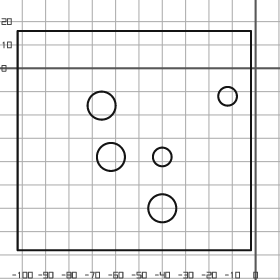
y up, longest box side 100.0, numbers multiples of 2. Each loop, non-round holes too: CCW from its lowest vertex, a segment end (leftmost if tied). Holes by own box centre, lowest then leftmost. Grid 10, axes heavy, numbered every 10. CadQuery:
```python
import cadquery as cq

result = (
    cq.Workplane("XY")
    .moveTo(-102.0, -78.0)
    .lineTo(-2.0, -78.0)
    .lineTo(-2.0, 16.0)
    .lineTo(-102.0, 16.0)
    .close()
    .moveTo(-40.0, -60.0)
    .circle(6.0)
    .moveTo(-62.0, -38.0)
    .circle(6.0)
    .moveTo(-40.0, -38.0)
    .circle(4.0)
    .moveTo(-66.0, -16.0)
    .circle(6.0)
    .moveTo(-12.0, -12.0)
    .circle(4.0)
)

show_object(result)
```